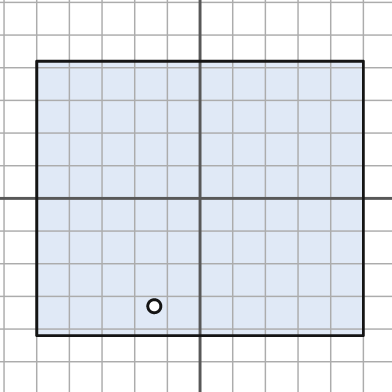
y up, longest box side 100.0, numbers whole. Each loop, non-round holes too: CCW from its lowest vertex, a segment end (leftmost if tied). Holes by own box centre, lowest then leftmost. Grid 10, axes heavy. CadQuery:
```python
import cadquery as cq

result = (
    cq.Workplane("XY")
    .moveTo(-50.0, -42.0)
    .lineTo(50.0, -42.0)
    .lineTo(50.0, 42.0)
    .lineTo(-50.0, 42.0)
    .close()
    .moveTo(-14.0, -33.0)
    .circle(2.0)
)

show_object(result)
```